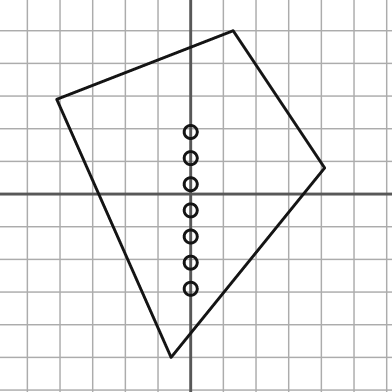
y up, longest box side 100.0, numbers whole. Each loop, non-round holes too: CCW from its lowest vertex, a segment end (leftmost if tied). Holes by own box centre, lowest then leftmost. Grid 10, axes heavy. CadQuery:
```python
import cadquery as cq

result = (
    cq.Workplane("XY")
    .moveTo(-6.0, -50.0)
    .lineTo(41.0, 8.0)
    .lineTo(13.0, 50.0)
    .lineTo(-41.0, 29.0)
    .close()
    .moveTo(0.0, -29.0)
    .circle(2.0)
    .moveTo(0.0, -21.0)
    .circle(2.0)
    .moveTo(0.0, -13.0)
    .circle(2.0)
    .moveTo(0.0, -5.0)
    .circle(2.0)
    .moveTo(0.0, 3.0)
    .circle(2.0)
    .moveTo(0.0, 11.0)
    .circle(2.0)
    .moveTo(0.0, 19.0)
    .circle(2.0)
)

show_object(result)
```